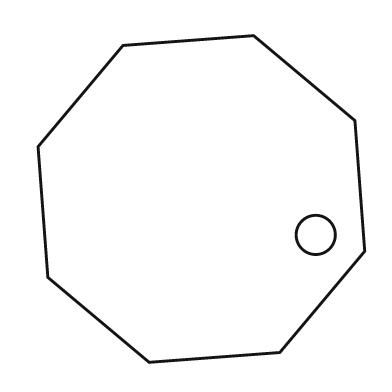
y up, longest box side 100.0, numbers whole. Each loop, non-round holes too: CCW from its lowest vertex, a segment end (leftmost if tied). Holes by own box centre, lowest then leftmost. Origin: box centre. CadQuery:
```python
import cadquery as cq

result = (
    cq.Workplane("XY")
    .moveTo(-16.0, -50.0)
    .lineTo(24.0, -47.0)
    .lineTo(50.0, -16.0)
    .lineTo(47.0, 24.0)
    .lineTo(16.0, 50.0)
    .lineTo(-24.0, 47.0)
    .lineTo(-50.0, 16.0)
    .lineTo(-47.0, -24.0)
    .close()
    .moveTo(35.0, -11.0)
    .circle(6.0)
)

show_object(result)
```